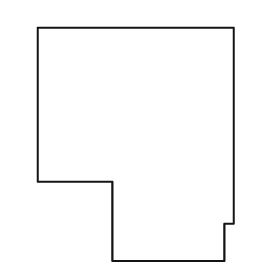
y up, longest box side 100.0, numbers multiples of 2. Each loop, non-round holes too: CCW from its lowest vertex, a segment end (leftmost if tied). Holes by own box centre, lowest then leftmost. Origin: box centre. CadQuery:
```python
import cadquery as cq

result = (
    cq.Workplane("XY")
    .moveTo(-10.0, -50.0)
    .lineTo(38.0, -50.0)
    .lineTo(38.0, -34.0)
    .lineTo(42.0, -34.0)
    .lineTo(42.0, 50.0)
    .lineTo(-42.0, 50.0)
    .lineTo(-42.0, -16.0)
    .lineTo(-10.0, -16.0)
    .close()
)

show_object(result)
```